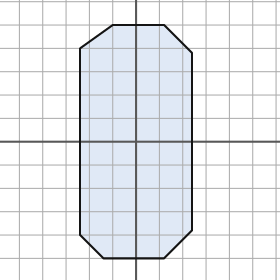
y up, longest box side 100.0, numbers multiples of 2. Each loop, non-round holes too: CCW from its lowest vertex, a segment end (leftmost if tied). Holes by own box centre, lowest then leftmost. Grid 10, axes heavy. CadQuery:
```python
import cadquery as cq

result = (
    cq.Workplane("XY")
    .moveTo(-14.0, -50.0)
    .lineTo(12.0, -50.0)
    .lineTo(24.0, -38.0)
    .lineTo(24.0, 38.0)
    .lineTo(12.0, 50.0)
    .lineTo(-10.0, 50.0)
    .lineTo(-24.0, 40.0)
    .lineTo(-24.0, -40.0)
    .close()
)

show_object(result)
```